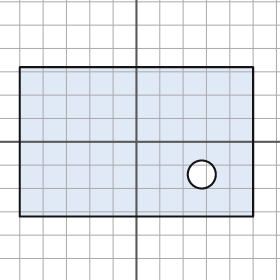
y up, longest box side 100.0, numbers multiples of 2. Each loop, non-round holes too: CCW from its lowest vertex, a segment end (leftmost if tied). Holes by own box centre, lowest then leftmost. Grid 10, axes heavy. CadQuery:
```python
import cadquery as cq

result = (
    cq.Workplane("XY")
    .moveTo(-50.0, -32.0)
    .lineTo(50.0, -32.0)
    .lineTo(50.0, 32.0)
    .lineTo(-50.0, 32.0)
    .close()
    .moveTo(28.0, -14.0)
    .circle(6.0)
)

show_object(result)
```